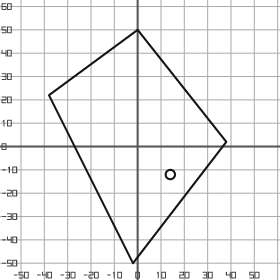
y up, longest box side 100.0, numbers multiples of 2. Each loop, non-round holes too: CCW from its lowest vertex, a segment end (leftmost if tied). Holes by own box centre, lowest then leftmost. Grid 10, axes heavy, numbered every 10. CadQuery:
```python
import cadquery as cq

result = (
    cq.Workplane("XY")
    .moveTo(-2.0, -50.0)
    .lineTo(38.0, 2.0)
    .lineTo(0.0, 50.0)
    .lineTo(-38.0, 22.0)
    .close()
    .moveTo(14.0, -12.0)
    .circle(2.0)
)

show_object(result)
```